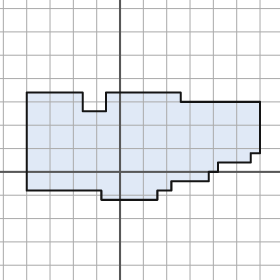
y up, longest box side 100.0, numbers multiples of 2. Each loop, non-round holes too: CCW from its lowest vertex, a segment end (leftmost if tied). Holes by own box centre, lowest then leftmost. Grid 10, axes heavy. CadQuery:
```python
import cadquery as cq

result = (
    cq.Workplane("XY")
    .moveTo(-8.0, -12.0)
    .lineTo(16.0, -12.0)
    .lineTo(16.0, -8.0)
    .lineTo(22.0, -8.0)
    .lineTo(22.0, -4.0)
    .lineTo(38.0, -4.0)
    .lineTo(38.0, 0.0)
    .lineTo(42.0, 0.0)
    .lineTo(42.0, 4.0)
    .lineTo(56.0, 4.0)
    .lineTo(56.0, 8.0)
    .lineTo(60.0, 8.0)
    .lineTo(60.0, 30.0)
    .lineTo(26.0, 30.0)
    .lineTo(26.0, 34.0)
    .lineTo(-6.0, 34.0)
    .lineTo(-6.0, 26.0)
    .lineTo(-16.0, 26.0)
    .lineTo(-16.0, 34.0)
    .lineTo(-40.0, 34.0)
    .lineTo(-40.0, -8.0)
    .lineTo(-8.0, -8.0)
    .close()
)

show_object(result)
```